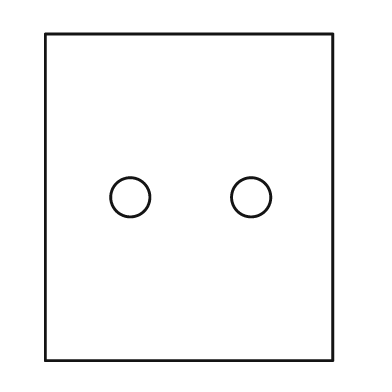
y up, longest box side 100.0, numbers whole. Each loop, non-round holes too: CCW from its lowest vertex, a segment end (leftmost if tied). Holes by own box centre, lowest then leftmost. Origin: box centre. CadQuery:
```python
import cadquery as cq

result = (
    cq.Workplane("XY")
    .moveTo(-44.0, -50.0)
    .lineTo(44.0, -50.0)
    .lineTo(44.0, 50.0)
    .lineTo(-44.0, 50.0)
    .close()
    .moveTo(-18.0, 0.0)
    .circle(6.0)
    .moveTo(19.0, 0.0)
    .circle(6.0)
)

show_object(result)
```